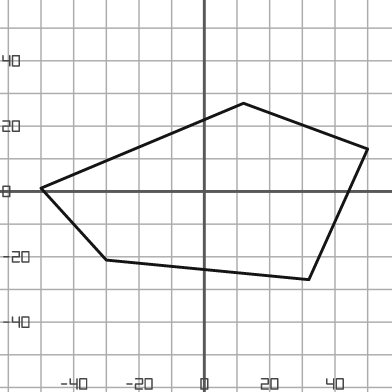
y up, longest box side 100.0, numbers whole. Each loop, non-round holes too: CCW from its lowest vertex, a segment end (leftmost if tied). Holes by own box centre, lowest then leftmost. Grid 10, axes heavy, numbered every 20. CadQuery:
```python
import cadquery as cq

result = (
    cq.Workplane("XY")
    .moveTo(32.0, -27.0)
    .lineTo(50.0, 13.0)
    .lineTo(12.0, 27.0)
    .lineTo(-50.0, 1.0)
    .lineTo(-30.0, -21.0)
    .close()
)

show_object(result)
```